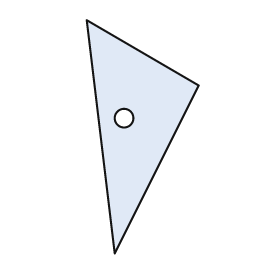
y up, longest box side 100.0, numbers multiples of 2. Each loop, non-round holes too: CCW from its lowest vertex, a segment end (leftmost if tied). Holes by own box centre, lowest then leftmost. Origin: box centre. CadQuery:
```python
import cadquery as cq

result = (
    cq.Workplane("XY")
    .moveTo(-12.0, -50.0)
    .lineTo(24.0, 22.0)
    .lineTo(-24.0, 50.0)
    .close()
    .moveTo(-8.0, 8.0)
    .circle(4.0)
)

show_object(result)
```